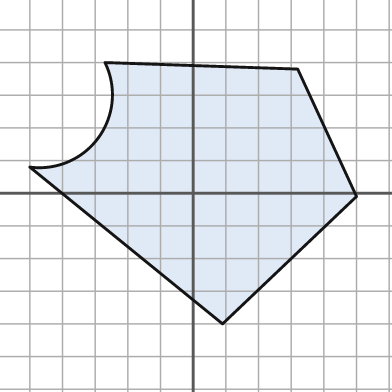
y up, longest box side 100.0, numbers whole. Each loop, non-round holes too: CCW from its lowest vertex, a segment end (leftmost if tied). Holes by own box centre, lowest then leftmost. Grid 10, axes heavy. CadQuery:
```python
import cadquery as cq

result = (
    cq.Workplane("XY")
    .moveTo(9.0, -40.0)
    .lineTo(50.0, -1.0)
    .lineTo(32.0, 38.0)
    .lineTo(-27.0, 40.0)
    .threePointArc((-29.0, 17.0), (-50.0, 8.0))
    .close()
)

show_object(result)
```